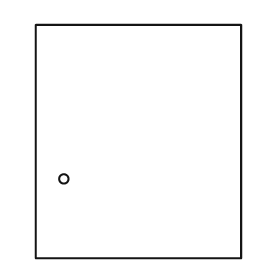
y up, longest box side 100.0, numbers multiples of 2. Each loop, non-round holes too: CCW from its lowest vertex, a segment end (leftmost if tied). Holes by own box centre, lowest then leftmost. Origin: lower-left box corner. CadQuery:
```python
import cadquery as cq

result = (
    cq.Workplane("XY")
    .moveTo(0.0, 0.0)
    .lineTo(88.0, 0.0)
    .lineTo(88.0, 100.0)
    .lineTo(0.0, 100.0)
    .close()
    .moveTo(12.0, 34.0)
    .circle(2.0)
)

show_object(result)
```